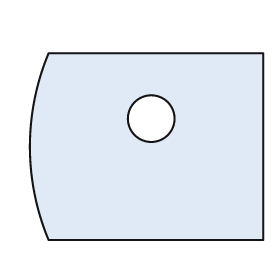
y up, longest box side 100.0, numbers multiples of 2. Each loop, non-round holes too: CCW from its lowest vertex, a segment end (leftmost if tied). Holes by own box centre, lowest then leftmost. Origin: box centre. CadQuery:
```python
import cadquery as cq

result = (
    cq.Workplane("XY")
    .moveTo(-42.0, -40.0)
    .lineTo(50.0, -40.0)
    .lineTo(50.0, 40.0)
    .lineTo(-42.0, 40.0)
    .threePointArc((-50.0, 0.0), (-42.0, -40.0))
    .close()
    .moveTo(2.0, 12.0)
    .circle(10.0)
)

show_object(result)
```